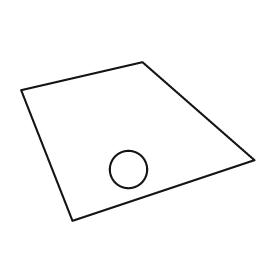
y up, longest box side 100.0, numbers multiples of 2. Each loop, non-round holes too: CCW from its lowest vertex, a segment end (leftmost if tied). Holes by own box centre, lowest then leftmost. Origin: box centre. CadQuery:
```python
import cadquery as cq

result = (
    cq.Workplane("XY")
    .moveTo(-28.0, -34.0)
    .lineTo(50.0, -8.0)
    .lineTo(2.0, 34.0)
    .lineTo(-50.0, 22.0)
    .close()
    .moveTo(-4.0, -12.0)
    .circle(8.0)
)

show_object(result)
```